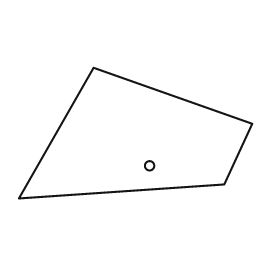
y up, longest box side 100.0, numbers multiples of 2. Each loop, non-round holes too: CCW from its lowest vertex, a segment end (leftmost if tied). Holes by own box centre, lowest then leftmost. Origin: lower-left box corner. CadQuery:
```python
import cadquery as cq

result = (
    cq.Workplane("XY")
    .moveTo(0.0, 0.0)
    .lineTo(88.0, 6.0)
    .lineTo(100.0, 32.0)
    .lineTo(32.0, 56.0)
    .close()
    .moveTo(56.0, 14.0)
    .circle(2.0)
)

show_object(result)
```